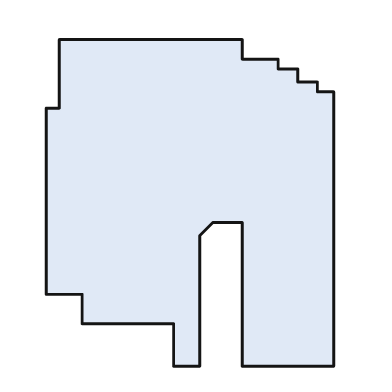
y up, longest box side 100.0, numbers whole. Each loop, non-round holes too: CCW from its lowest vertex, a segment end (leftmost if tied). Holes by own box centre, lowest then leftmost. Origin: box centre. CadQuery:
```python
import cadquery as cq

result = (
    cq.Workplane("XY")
    .moveTo(-5.0, -50.0)
    .lineTo(3.0, -50.0)
    .lineTo(3.0, -10.0)
    .lineTo(7.0, -6.0)
    .lineTo(16.0, -6.0)
    .lineTo(16.0, -50.0)
    .lineTo(44.0, -50.0)
    .lineTo(44.0, 34.0)
    .lineTo(39.0, 34.0)
    .lineTo(39.0, 37.0)
    .lineTo(33.0, 37.0)
    .lineTo(33.0, 41.0)
    .lineTo(27.0, 41.0)
    .lineTo(27.0, 44.0)
    .lineTo(16.0, 44.0)
    .lineTo(16.0, 50.0)
    .lineTo(-40.0, 50.0)
    .lineTo(-40.0, 29.0)
    .lineTo(-44.0, 29.0)
    .lineTo(-44.0, -28.0)
    .lineTo(-33.0, -28.0)
    .lineTo(-33.0, -37.0)
    .lineTo(-5.0, -37.0)
    .close()
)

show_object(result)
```